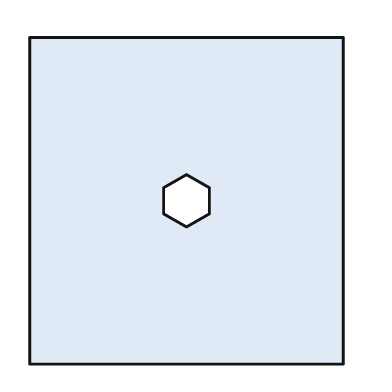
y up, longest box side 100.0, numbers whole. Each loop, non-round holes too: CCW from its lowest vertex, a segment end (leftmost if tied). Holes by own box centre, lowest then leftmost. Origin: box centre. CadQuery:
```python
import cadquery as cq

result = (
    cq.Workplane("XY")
    .moveTo(-48.0, -50.0)
    .lineTo(48.0, -50.0)
    .lineTo(48.0, 50.0)
    .lineTo(-48.0, 50.0)
    .close()
    .moveTo(0.0, -8.0)
    .lineTo(7.0, -4.0)
    .lineTo(7.0, 4.0)
    .lineTo(0.0, 8.0)
    .lineTo(-7.0, 4.0)
    .lineTo(-7.0, -4.0)
    .close()
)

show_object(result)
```